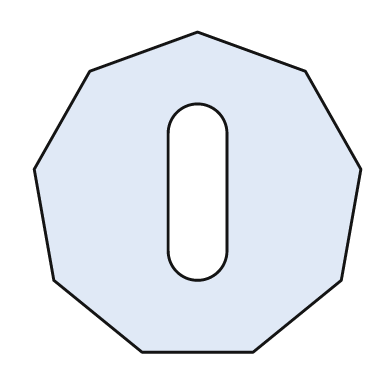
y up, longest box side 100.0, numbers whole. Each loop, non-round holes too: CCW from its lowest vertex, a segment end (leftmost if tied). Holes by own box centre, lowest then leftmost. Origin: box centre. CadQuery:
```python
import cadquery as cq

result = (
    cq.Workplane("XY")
    .moveTo(-17.0, -49.0)
    .lineTo(17.0, -49.0)
    .lineTo(44.0, -27.0)
    .lineTo(50.0, 7.0)
    .lineTo(33.0, 37.0)
    .lineTo(0.0, 49.0)
    .lineTo(-33.0, 37.0)
    .lineTo(-50.0, 7.0)
    .lineTo(-44.0, -27.0)
    .close()
    .moveTo(-9.0, -18.0)
    .threePointArc((0.0, -27.0), (9.0, -18.0))
    .lineTo(9.0, 18.0)
    .threePointArc((0.0, 27.0), (-9.0, 18.0))
    .close()
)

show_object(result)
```